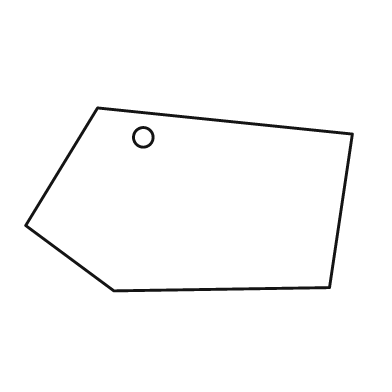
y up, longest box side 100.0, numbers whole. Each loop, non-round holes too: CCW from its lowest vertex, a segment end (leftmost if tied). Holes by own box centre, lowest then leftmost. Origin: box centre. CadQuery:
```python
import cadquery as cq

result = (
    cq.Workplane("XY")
    .moveTo(-23.0, -28.0)
    .lineTo(43.0, -27.0)
    .lineTo(50.0, 20.0)
    .lineTo(-28.0, 28.0)
    .lineTo(-50.0, -8.0)
    .close()
    .moveTo(-14.0, 19.0)
    .circle(3.0)
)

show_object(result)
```